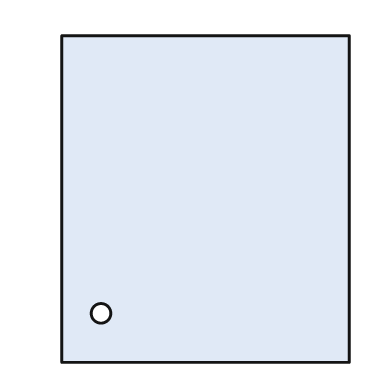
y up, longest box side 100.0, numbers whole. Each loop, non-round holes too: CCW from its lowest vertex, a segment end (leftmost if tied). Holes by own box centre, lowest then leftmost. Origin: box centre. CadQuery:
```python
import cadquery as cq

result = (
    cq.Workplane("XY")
    .moveTo(-44.0, -50.0)
    .lineTo(44.0, -50.0)
    .lineTo(44.0, 50.0)
    .lineTo(-44.0, 50.0)
    .close()
    .moveTo(-32.0, -35.0)
    .circle(3.0)
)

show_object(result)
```